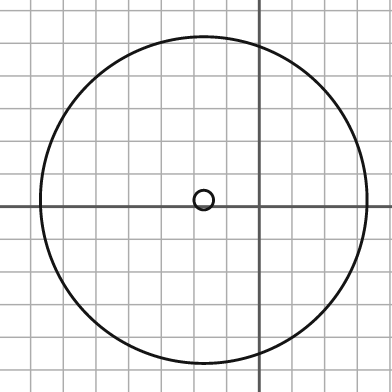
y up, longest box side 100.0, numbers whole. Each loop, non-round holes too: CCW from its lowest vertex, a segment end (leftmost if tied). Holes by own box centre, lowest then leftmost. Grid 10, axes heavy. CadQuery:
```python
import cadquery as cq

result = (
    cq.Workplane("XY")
    .moveTo(-17.0, 2.0)
    .circle(50.0)
    .moveTo(-17.0, 2.0)
    .circle(3.0)
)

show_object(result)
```